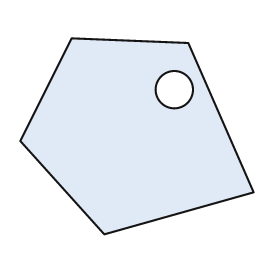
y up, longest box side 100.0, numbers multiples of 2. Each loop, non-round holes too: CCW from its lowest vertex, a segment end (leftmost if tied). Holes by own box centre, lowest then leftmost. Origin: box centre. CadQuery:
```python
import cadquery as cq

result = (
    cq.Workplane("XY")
    .moveTo(-14.0, -42.0)
    .lineTo(50.0, -24.0)
    .lineTo(22.0, 40.0)
    .lineTo(-28.0, 42.0)
    .lineTo(-50.0, -2.0)
    .close()
    .moveTo(16.0, 20.0)
    .circle(8.0)
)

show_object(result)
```